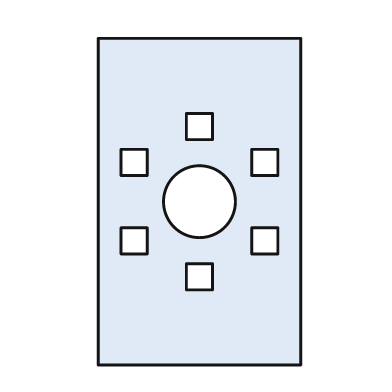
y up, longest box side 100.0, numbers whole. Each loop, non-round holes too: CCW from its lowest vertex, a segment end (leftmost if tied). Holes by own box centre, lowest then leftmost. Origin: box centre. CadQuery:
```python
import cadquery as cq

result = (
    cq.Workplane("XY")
    .moveTo(-31.0, -50.0)
    .lineTo(31.0, -50.0)
    .lineTo(31.0, 50.0)
    .lineTo(-31.0, 50.0)
    .close()
    .moveTo(-4.0, -27.0)
    .lineTo(4.0, -27.0)
    .lineTo(4.0, -19.0)
    .lineTo(-4.0, -19.0)
    .close()
    .moveTo(-24.0, -16.0)
    .lineTo(-16.0, -16.0)
    .lineTo(-16.0, -8.0)
    .lineTo(-24.0, -8.0)
    .close()
    .moveTo(16.0, -16.0)
    .lineTo(24.0, -16.0)
    .lineTo(24.0, -8.0)
    .lineTo(16.0, -8.0)
    .close()
    .moveTo(0.0, 0.0)
    .circle(11.0)
    .moveTo(-24.0, 8.0)
    .lineTo(-16.0, 8.0)
    .lineTo(-16.0, 16.0)
    .lineTo(-24.0, 16.0)
    .close()
    .moveTo(16.0, 8.0)
    .lineTo(24.0, 8.0)
    .lineTo(24.0, 16.0)
    .lineTo(16.0, 16.0)
    .close()
    .moveTo(-4.0, 19.0)
    .lineTo(4.0, 19.0)
    .lineTo(4.0, 27.0)
    .lineTo(-4.0, 27.0)
    .close()
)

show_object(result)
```